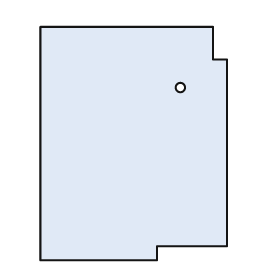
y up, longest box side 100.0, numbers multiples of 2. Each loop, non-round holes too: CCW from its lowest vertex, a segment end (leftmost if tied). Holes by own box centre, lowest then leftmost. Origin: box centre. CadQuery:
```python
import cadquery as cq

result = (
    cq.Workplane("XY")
    .moveTo(-40.0, -50.0)
    .lineTo(10.0, -50.0)
    .lineTo(10.0, -44.0)
    .lineTo(40.0, -44.0)
    .lineTo(40.0, 36.0)
    .lineTo(34.0, 36.0)
    .lineTo(34.0, 50.0)
    .lineTo(-40.0, 50.0)
    .close()
    .moveTo(20.0, 24.0)
    .circle(2.0)
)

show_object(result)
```